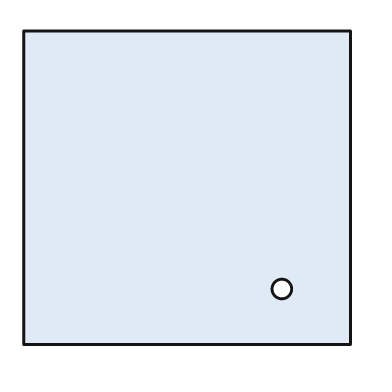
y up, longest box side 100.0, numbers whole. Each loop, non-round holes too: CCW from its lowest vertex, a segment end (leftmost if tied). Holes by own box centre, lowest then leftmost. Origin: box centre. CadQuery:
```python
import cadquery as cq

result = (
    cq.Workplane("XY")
    .moveTo(-50.0, -48.0)
    .lineTo(50.0, -48.0)
    .lineTo(50.0, 48.0)
    .lineTo(-50.0, 48.0)
    .close()
    .moveTo(29.0, -31.0)
    .circle(3.0)
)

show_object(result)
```